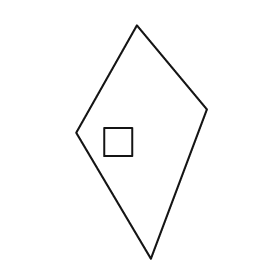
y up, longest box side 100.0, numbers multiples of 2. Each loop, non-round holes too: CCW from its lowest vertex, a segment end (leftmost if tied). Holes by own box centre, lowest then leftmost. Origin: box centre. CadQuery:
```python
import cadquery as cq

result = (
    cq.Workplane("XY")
    .moveTo(4.0, -50.0)
    .lineTo(28.0, 14.0)
    .lineTo(-2.0, 50.0)
    .lineTo(-28.0, 4.0)
    .close()
    .moveTo(-16.0, -6.0)
    .lineTo(-4.0, -6.0)
    .lineTo(-4.0, 6.0)
    .lineTo(-16.0, 6.0)
    .close()
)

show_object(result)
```